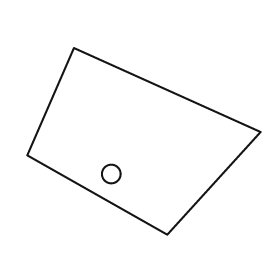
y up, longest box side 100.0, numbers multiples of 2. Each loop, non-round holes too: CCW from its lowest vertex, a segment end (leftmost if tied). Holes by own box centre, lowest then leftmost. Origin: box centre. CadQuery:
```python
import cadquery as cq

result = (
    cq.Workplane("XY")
    .moveTo(10.0, -40.0)
    .lineTo(50.0, 4.0)
    .lineTo(-30.0, 40.0)
    .lineTo(-50.0, -6.0)
    .close()
    .moveTo(-14.0, -14.0)
    .circle(4.0)
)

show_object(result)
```